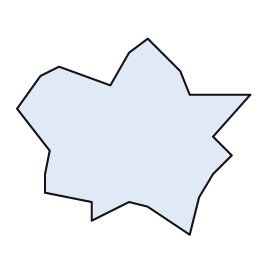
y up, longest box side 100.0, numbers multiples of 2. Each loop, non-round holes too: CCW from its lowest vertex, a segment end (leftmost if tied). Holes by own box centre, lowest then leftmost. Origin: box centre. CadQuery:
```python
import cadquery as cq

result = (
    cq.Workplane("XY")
    .moveTo(24.0, -42.0)
    .lineTo(28.0, -26.0)
    .lineTo(34.0, -16.0)
    .lineTo(42.0, -8.0)
    .lineTo(34.0, 0.0)
    .lineTo(50.0, 18.0)
    .lineTo(24.0, 18.0)
    .lineTo(20.0, 28.0)
    .lineTo(6.0, 42.0)
    .lineTo(-2.0, 36.0)
    .lineTo(-10.0, 22.0)
    .lineTo(-32.0, 30.0)
    .lineTo(-40.0, 26.0)
    .lineTo(-50.0, 12.0)
    .lineTo(-36.0, -6.0)
    .lineTo(-38.0, -16.0)
    .lineTo(-38.0, -24.0)
    .lineTo(-18.0, -28.0)
    .lineTo(-18.0, -36.0)
    .lineTo(-2.0, -28.0)
    .lineTo(6.0, -30.0)
    .close()
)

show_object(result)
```